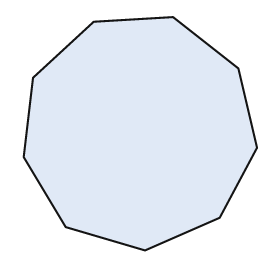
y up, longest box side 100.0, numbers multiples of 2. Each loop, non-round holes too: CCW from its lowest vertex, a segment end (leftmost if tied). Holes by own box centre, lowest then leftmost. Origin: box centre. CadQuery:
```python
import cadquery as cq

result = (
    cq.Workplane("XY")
    .moveTo(2.0, -50.0)
    .lineTo(34.0, -36.0)
    .lineTo(50.0, -6.0)
    .lineTo(42.0, 28.0)
    .lineTo(14.0, 50.0)
    .lineTo(-20.0, 48.0)
    .lineTo(-46.0, 24.0)
    .lineTo(-50.0, -10.0)
    .lineTo(-32.0, -40.0)
    .close()
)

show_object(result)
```